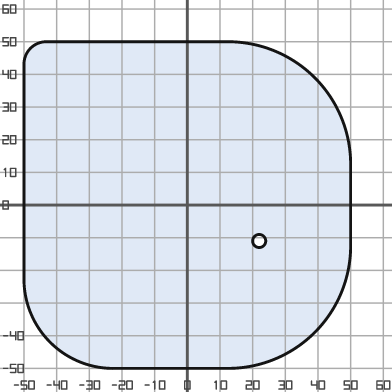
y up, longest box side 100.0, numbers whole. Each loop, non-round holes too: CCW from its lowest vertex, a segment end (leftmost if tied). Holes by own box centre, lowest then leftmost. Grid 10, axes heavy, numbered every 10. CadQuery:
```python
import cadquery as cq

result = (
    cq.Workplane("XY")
    .moveTo(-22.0, -50.0)
    .lineTo(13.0, -50.0)
    .threePointArc((39.0, -39.0), (50.0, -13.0))
    .lineTo(50.0, 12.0)
    .threePointArc((39.0, 39.0), (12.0, 50.0))
    .lineTo(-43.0, 50.0)
    .threePointArc((-48.0, 48.0), (-50.0, 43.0))
    .lineTo(-50.0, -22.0)
    .threePointArc((-42.0, -42.0), (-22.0, -50.0))
    .close()
    .moveTo(22.0, -11.0)
    .circle(2.0)
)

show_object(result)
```